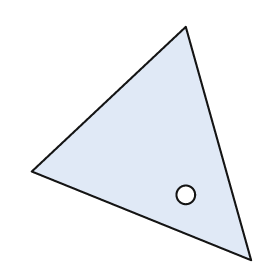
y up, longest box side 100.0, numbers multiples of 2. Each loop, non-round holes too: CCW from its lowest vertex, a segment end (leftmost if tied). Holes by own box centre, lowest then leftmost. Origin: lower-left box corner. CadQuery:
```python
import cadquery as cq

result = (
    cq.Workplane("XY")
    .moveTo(94.0, 0.0)
    .lineTo(66.0, 100.0)
    .lineTo(0.0, 38.0)
    .close()
    .moveTo(66.0, 28.0)
    .circle(4.0)
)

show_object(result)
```